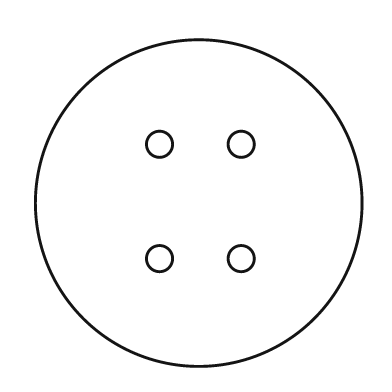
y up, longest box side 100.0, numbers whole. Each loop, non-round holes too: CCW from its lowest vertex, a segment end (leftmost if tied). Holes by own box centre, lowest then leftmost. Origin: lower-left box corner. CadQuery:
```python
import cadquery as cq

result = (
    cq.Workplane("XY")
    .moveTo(50.0, 50.0)
    .circle(50.0)
    .moveTo(38.0, 33.0)
    .circle(4.0)
    .moveTo(63.0, 33.0)
    .circle(4.0)
    .moveTo(38.0, 68.0)
    .circle(4.0)
    .moveTo(63.0, 68.0)
    .circle(4.0)
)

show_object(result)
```